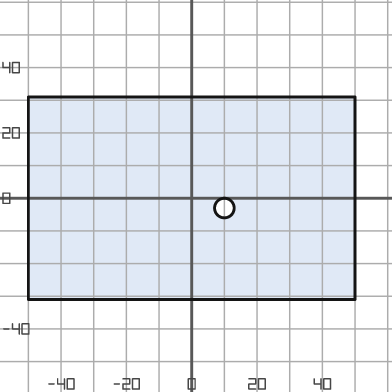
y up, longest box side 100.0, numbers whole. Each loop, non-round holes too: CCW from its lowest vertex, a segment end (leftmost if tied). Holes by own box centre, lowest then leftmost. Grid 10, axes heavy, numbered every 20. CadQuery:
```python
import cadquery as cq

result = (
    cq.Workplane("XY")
    .moveTo(-50.0, -31.0)
    .lineTo(50.0, -31.0)
    .lineTo(50.0, 31.0)
    .lineTo(-50.0, 31.0)
    .close()
    .moveTo(10.0, -3.0)
    .circle(3.0)
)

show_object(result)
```